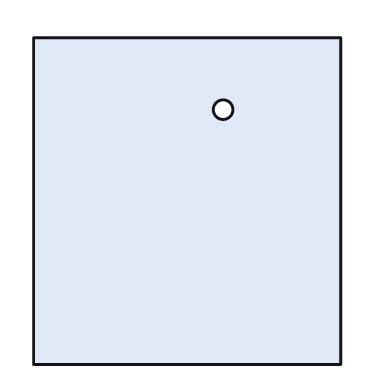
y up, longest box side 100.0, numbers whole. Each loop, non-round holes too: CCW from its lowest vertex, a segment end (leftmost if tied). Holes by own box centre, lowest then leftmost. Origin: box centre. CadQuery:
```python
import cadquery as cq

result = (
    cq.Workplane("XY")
    .moveTo(-47.0, -50.0)
    .lineTo(47.0, -50.0)
    .lineTo(47.0, 50.0)
    .lineTo(-47.0, 50.0)
    .close()
    .moveTo(11.0, 28.0)
    .circle(3.0)
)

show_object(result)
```